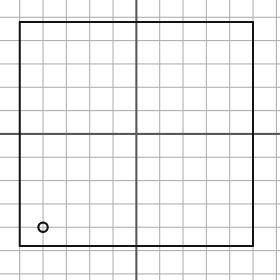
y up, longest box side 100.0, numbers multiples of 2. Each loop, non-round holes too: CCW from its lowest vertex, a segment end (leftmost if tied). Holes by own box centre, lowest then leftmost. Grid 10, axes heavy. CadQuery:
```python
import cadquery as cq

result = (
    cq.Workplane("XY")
    .moveTo(-50.0, -48.0)
    .lineTo(50.0, -48.0)
    .lineTo(50.0, 48.0)
    .lineTo(-50.0, 48.0)
    .close()
    .moveTo(-40.0, -40.0)
    .circle(2.0)
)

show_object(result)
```